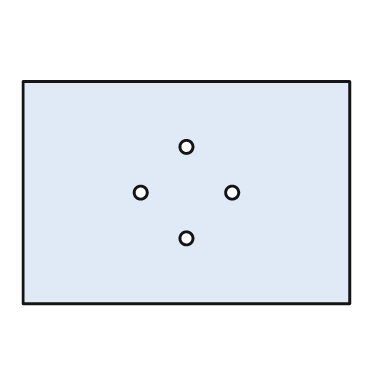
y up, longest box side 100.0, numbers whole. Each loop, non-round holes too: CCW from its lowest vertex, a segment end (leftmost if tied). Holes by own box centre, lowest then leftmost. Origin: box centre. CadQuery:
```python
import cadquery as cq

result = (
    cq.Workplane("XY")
    .moveTo(-50.0, -34.0)
    .lineTo(50.0, -34.0)
    .lineTo(50.0, 34.0)
    .lineTo(-50.0, 34.0)
    .close()
    .moveTo(0.0, -14.0)
    .circle(2.0)
    .moveTo(-14.0, 0.0)
    .circle(2.0)
    .moveTo(14.0, 0.0)
    .circle(2.0)
    .moveTo(0.0, 14.0)
    .circle(2.0)
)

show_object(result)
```